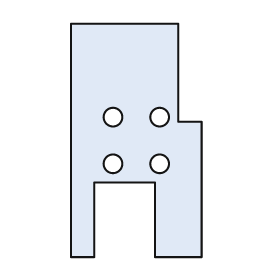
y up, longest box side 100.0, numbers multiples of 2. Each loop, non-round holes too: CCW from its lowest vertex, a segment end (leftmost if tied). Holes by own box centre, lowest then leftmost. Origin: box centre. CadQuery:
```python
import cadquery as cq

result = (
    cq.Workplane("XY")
    .moveTo(-28.0, -50.0)
    .lineTo(-18.0, -50.0)
    .lineTo(-18.0, -18.0)
    .lineTo(8.0, -18.0)
    .lineTo(8.0, -50.0)
    .lineTo(28.0, -50.0)
    .lineTo(28.0, 8.0)
    .lineTo(18.0, 8.0)
    .lineTo(18.0, 50.0)
    .lineTo(-28.0, 50.0)
    .close()
    .moveTo(-10.0, -10.0)
    .circle(4.0)
    .moveTo(10.0, -10.0)
    .circle(4.0)
    .moveTo(-10.0, 10.0)
    .circle(4.0)
    .moveTo(10.0, 10.0)
    .circle(4.0)
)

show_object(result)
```